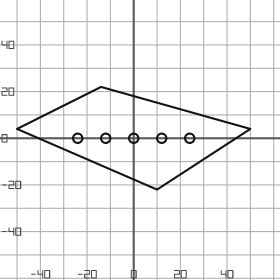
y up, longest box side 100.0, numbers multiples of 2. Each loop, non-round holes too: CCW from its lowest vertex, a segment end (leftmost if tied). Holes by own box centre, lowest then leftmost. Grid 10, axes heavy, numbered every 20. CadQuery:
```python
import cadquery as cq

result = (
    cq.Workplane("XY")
    .moveTo(10.0, -22.0)
    .lineTo(50.0, 4.0)
    .lineTo(-14.0, 22.0)
    .lineTo(-50.0, 4.0)
    .close()
    .moveTo(-24.0, 0.0)
    .circle(2.0)
    .moveTo(-12.0, 0.0)
    .circle(2.0)
    .moveTo(0.0, 0.0)
    .circle(2.0)
    .moveTo(12.0, 0.0)
    .circle(2.0)
    .moveTo(24.0, 0.0)
    .circle(2.0)
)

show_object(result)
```